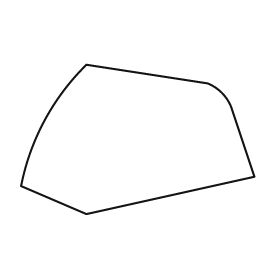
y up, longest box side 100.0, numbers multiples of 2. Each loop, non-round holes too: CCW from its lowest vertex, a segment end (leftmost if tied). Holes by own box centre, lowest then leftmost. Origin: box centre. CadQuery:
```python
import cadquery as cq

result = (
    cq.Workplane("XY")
    .moveTo(-22.0, -32.0)
    .lineTo(50.0, -16.0)
    .lineTo(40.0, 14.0)
    .threePointArc((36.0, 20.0), (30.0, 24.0))
    .lineTo(-22.0, 32.0)
    .threePointArc((-40.0, 8.0), (-50.0, -20.0))
    .close()
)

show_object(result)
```